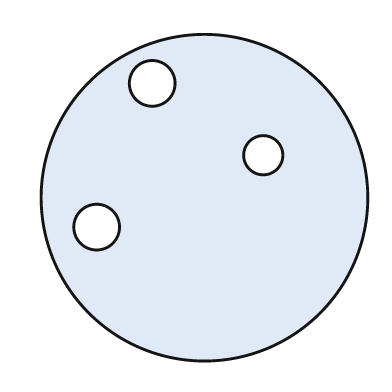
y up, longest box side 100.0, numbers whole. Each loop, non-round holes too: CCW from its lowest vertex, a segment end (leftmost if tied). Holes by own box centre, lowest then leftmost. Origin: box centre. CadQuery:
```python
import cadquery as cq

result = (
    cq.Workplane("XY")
    .moveTo(0.0, 0.0)
    .circle(50.0)
    .moveTo(-33.0, -9.0)
    .circle(7.0)
    .moveTo(18.0, 13.0)
    .circle(6.0)
    .moveTo(-16.0, 35.0)
    .circle(7.0)
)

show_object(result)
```